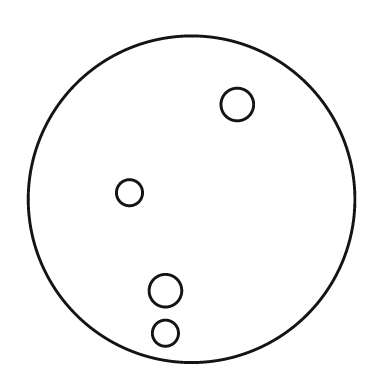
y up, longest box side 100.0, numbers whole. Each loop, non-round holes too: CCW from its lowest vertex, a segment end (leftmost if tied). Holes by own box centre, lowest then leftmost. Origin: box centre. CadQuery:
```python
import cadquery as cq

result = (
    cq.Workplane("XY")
    .moveTo(0.0, 0.0)
    .circle(50.0)
    .moveTo(-8.0, -41.0)
    .circle(4.0)
    .moveTo(-8.0, -28.0)
    .circle(5.0)
    .moveTo(-19.0, 2.0)
    .circle(4.0)
    .moveTo(14.0, 29.0)
    .circle(5.0)
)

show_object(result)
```